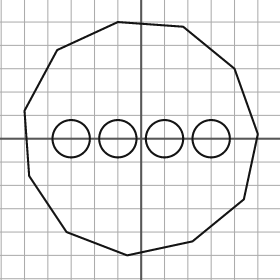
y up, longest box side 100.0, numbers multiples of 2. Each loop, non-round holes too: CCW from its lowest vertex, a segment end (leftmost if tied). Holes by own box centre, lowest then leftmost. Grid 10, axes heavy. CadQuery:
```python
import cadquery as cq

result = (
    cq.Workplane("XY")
    .moveTo(-6.0, -50.0)
    .lineTo(22.0, -44.0)
    .lineTo(44.0, -26.0)
    .lineTo(50.0, 2.0)
    .lineTo(40.0, 30.0)
    .lineTo(18.0, 48.0)
    .lineTo(-10.0, 50.0)
    .lineTo(-36.0, 38.0)
    .lineTo(-50.0, 12.0)
    .lineTo(-48.0, -16.0)
    .lineTo(-32.0, -40.0)
    .close()
    .moveTo(-30.0, 0.0)
    .circle(8.0)
    .moveTo(-10.0, 0.0)
    .circle(8.0)
    .moveTo(10.0, 0.0)
    .circle(8.0)
    .moveTo(30.0, 0.0)
    .circle(8.0)
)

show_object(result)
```